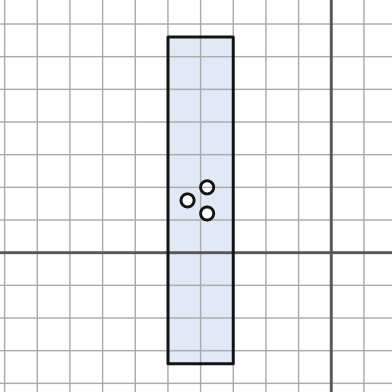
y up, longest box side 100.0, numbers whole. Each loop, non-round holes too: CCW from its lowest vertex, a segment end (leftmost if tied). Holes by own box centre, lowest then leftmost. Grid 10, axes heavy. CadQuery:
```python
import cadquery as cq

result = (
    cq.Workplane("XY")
    .moveTo(-50.0, -34.0)
    .lineTo(-30.0, -34.0)
    .lineTo(-30.0, 66.0)
    .lineTo(-50.0, 66.0)
    .close()
    .moveTo(-38.0, 12.0)
    .circle(2.0)
    .moveTo(-44.0, 16.0)
    .circle(2.0)
    .moveTo(-38.0, 20.0)
    .circle(2.0)
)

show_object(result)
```